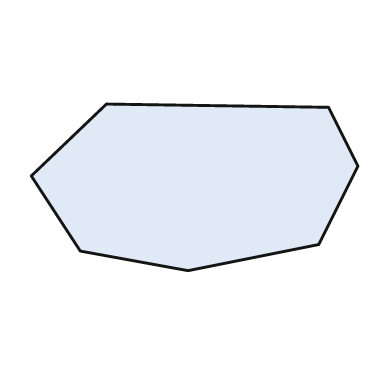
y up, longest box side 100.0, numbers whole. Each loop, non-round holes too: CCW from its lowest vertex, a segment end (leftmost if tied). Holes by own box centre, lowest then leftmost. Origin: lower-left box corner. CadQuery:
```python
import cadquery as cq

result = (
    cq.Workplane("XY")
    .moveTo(48.0, 0.0)
    .lineTo(88.0, 8.0)
    .lineTo(100.0, 32.0)
    .lineTo(91.0, 50.0)
    .lineTo(23.0, 51.0)
    .lineTo(0.0, 29.0)
    .lineTo(15.0, 6.0)
    .close()
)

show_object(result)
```